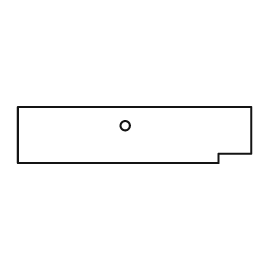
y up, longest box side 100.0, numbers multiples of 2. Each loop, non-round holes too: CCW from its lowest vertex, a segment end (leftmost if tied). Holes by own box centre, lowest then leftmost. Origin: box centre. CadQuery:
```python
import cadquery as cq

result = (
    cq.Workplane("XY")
    .moveTo(-50.0, -12.0)
    .lineTo(36.0, -12.0)
    .lineTo(36.0, -8.0)
    .lineTo(50.0, -8.0)
    .lineTo(50.0, 12.0)
    .lineTo(-50.0, 12.0)
    .close()
    .moveTo(-4.0, 4.0)
    .circle(2.0)
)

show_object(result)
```